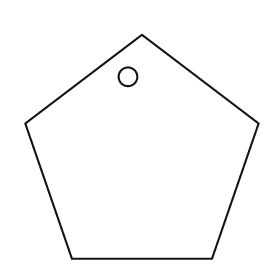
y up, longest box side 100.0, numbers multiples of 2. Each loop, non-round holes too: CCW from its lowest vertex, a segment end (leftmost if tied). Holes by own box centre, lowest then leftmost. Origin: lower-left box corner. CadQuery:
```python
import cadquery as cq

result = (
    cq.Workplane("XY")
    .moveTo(20.0, 0.0)
    .lineTo(80.0, 0.0)
    .lineTo(100.0, 58.0)
    .lineTo(50.0, 96.0)
    .lineTo(0.0, 58.0)
    .close()
    .moveTo(44.0, 78.0)
    .circle(4.0)
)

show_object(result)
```